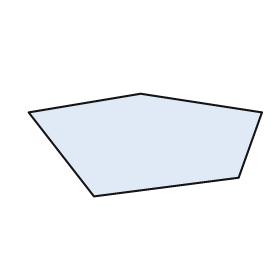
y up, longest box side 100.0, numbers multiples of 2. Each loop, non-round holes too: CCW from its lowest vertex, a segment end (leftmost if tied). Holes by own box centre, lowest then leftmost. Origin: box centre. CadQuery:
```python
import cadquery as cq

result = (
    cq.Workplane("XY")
    .moveTo(-22.0, -22.0)
    .lineTo(40.0, -14.0)
    .lineTo(50.0, 14.0)
    .lineTo(-2.0, 22.0)
    .lineTo(-50.0, 14.0)
    .close()
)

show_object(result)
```